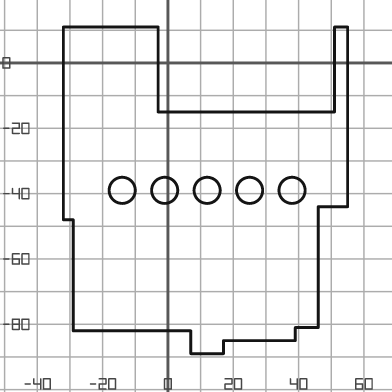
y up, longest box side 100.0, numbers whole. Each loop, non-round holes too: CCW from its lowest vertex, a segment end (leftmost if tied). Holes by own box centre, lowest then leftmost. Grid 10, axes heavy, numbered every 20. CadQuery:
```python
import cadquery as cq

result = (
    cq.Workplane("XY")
    .moveTo(7.0, -89.0)
    .lineTo(17.0, -89.0)
    .lineTo(17.0, -85.0)
    .lineTo(39.0, -85.0)
    .lineTo(39.0, -81.0)
    .lineTo(46.0, -81.0)
    .lineTo(46.0, -44.0)
    .lineTo(55.0, -44.0)
    .lineTo(55.0, 11.0)
    .lineTo(51.0, 11.0)
    .lineTo(51.0, -15.0)
    .lineTo(-3.0, -15.0)
    .lineTo(-3.0, 11.0)
    .lineTo(-32.0, 11.0)
    .lineTo(-32.0, -48.0)
    .lineTo(-29.0, -48.0)
    .lineTo(-29.0, -82.0)
    .lineTo(7.0, -82.0)
    .close()
    .moveTo(-14.0, -39.0)
    .circle(4.0)
    .moveTo(-1.0, -39.0)
    .circle(4.0)
    .moveTo(12.0, -39.0)
    .circle(4.0)
    .moveTo(25.0, -39.0)
    .circle(4.0)
    .moveTo(38.0, -39.0)
    .circle(4.0)
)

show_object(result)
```